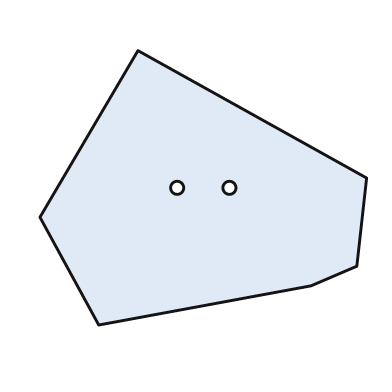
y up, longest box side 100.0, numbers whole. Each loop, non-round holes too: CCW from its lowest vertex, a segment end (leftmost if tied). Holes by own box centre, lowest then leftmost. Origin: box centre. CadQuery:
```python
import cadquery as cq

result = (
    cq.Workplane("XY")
    .moveTo(-32.0, -42.0)
    .lineTo(33.0, -30.0)
    .lineTo(47.0, -24.0)
    .lineTo(50.0, 3.0)
    .lineTo(-20.0, 42.0)
    .lineTo(-50.0, -9.0)
    .close()
    .moveTo(-8.0, 0.0)
    .circle(2.0)
    .moveTo(8.0, 0.0)
    .circle(2.0)
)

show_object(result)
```